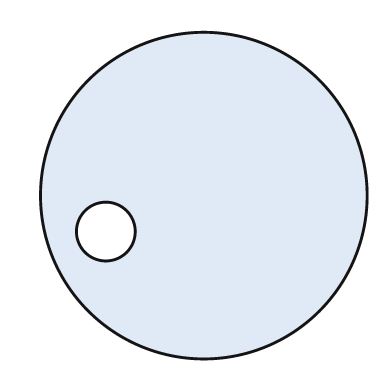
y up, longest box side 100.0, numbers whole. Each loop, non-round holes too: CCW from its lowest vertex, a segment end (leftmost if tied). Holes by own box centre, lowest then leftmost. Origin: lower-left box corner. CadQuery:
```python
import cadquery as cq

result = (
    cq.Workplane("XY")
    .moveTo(50.0, 50.0)
    .circle(50.0)
    .moveTo(20.0, 39.0)
    .circle(9.0)
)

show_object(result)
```